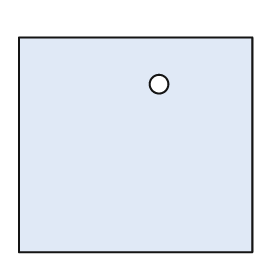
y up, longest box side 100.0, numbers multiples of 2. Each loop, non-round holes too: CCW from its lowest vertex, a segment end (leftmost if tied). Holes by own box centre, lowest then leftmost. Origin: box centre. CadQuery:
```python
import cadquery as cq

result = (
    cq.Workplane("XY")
    .moveTo(-50.0, -46.0)
    .lineTo(50.0, -46.0)
    .lineTo(50.0, 46.0)
    .lineTo(-50.0, 46.0)
    .close()
    .moveTo(10.0, 26.0)
    .circle(4.0)
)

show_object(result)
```